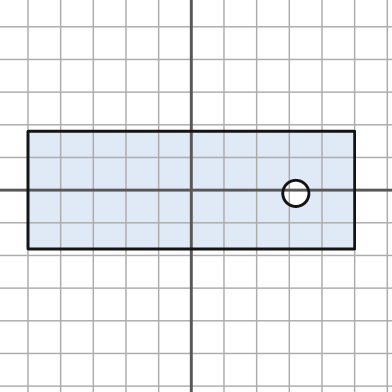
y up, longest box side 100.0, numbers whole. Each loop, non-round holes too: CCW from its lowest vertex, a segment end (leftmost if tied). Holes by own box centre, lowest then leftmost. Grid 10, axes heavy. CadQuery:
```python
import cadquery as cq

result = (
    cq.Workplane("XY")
    .moveTo(-50.0, -18.0)
    .lineTo(50.0, -18.0)
    .lineTo(50.0, 18.0)
    .lineTo(-50.0, 18.0)
    .close()
    .moveTo(32.0, -1.0)
    .circle(4.0)
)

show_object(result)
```